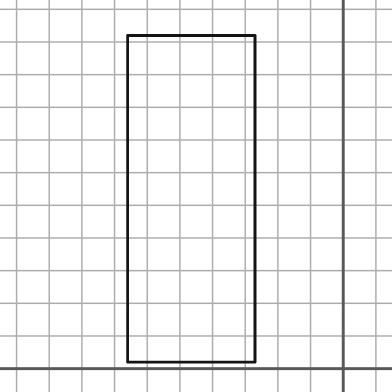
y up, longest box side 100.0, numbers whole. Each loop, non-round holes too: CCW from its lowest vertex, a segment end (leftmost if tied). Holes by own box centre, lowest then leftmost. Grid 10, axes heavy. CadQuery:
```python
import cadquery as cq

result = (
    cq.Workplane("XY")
    .moveTo(-66.0, 2.0)
    .lineTo(-27.0, 2.0)
    .lineTo(-27.0, 102.0)
    .lineTo(-66.0, 102.0)
    .close()
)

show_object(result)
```